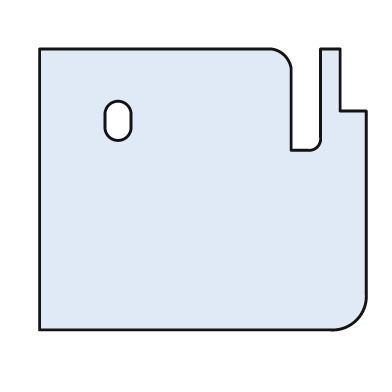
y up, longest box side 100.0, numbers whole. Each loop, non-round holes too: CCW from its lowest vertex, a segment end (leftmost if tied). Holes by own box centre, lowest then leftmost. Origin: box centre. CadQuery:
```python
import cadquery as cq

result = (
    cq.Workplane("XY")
    .moveTo(-50.0, -43.0)
    .lineTo(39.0, -43.0)
    .threePointArc((47.0, -40.0), (50.0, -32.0))
    .lineTo(50.0, 24.0)
    .lineTo(42.0, 24.0)
    .lineTo(42.0, 43.0)
    .lineTo(36.0, 43.0)
    .lineTo(36.0, 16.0)
    .threePointArc((35.0, 13.0), (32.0, 12.0))
    .lineTo(27.0, 12.0)
    .lineTo(27.0, 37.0)
    .threePointArc((25.0, 41.0), (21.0, 43.0))
    .lineTo(-50.0, 43.0)
    .close()
    .moveTo(-30.0, 19.0)
    .threePointArc((-26.0, 15.0), (-22.0, 19.0))
    .lineTo(-22.0, 23.0)
    .threePointArc((-26.0, 27.0), (-30.0, 23.0))
    .close()
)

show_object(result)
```